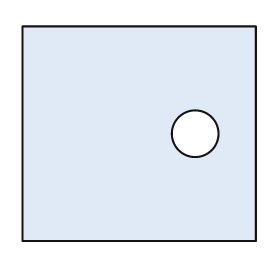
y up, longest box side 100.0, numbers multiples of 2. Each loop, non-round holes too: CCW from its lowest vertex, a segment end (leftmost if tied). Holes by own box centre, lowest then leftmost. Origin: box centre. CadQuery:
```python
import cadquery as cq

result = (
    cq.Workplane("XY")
    .moveTo(-50.0, -46.0)
    .lineTo(50.0, -46.0)
    .lineTo(50.0, 46.0)
    .lineTo(-50.0, 46.0)
    .close()
    .moveTo(24.0, 0.0)
    .circle(10.0)
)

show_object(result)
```